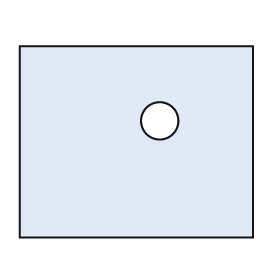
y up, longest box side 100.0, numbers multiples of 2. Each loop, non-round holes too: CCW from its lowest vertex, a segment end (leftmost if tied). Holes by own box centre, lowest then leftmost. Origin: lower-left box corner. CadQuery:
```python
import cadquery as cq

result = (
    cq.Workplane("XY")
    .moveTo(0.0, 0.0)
    .lineTo(100.0, 0.0)
    .lineTo(100.0, 82.0)
    .lineTo(0.0, 82.0)
    .close()
    .moveTo(60.0, 50.0)
    .circle(8.0)
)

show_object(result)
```